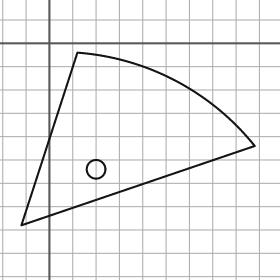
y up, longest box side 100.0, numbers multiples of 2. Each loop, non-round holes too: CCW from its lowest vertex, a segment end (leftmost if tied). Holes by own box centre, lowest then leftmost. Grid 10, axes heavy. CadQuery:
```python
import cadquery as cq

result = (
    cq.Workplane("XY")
    .moveTo(-12.0, -78.0)
    .lineTo(88.0, -44.0)
    .threePointArc((54.0, -16.0), (12.0, -4.0))
    .close()
    .moveTo(20.0, -54.0)
    .circle(4.0)
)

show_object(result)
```